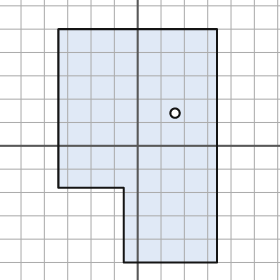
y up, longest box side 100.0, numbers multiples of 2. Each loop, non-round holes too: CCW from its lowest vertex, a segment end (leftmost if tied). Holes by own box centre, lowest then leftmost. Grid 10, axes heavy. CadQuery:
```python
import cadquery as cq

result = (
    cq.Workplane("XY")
    .moveTo(-6.0, -50.0)
    .lineTo(34.0, -50.0)
    .lineTo(34.0, 50.0)
    .lineTo(-34.0, 50.0)
    .lineTo(-34.0, -18.0)
    .lineTo(-6.0, -18.0)
    .close()
    .moveTo(16.0, 14.0)
    .circle(2.0)
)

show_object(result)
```